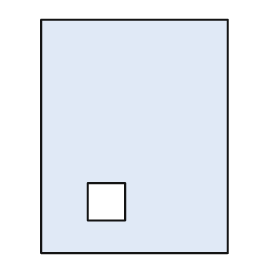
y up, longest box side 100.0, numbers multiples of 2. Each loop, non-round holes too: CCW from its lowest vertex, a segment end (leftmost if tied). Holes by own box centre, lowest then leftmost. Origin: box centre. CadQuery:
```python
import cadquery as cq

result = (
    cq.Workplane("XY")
    .moveTo(-40.0, -50.0)
    .lineTo(40.0, -50.0)
    .lineTo(40.0, 50.0)
    .lineTo(-40.0, 50.0)
    .close()
    .moveTo(-20.0, -36.0)
    .lineTo(-4.0, -36.0)
    .lineTo(-4.0, -20.0)
    .lineTo(-20.0, -20.0)
    .close()
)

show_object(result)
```